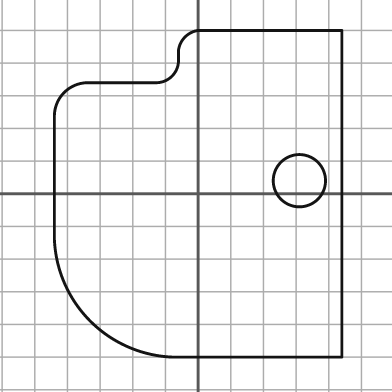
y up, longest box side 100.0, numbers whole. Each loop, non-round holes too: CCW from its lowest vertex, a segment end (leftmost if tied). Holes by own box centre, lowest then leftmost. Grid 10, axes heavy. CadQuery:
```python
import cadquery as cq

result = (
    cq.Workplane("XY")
    .moveTo(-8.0, -50.0)
    .lineTo(44.0, -50.0)
    .lineTo(44.0, 50.0)
    .lineTo(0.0, 50.0)
    .threePointArc((-4.0, 48.0), (-6.0, 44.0))
    .lineTo(-6.0, 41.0)
    .threePointArc((-8.0, 36.0), (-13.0, 34.0))
    .lineTo(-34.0, 34.0)
    .threePointArc((-41.0, 31.0), (-44.0, 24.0))
    .lineTo(-44.0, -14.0)
    .threePointArc((-33.0, -39.0), (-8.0, -50.0))
    .close()
    .moveTo(31.0, 4.0)
    .circle(8.0)
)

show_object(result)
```